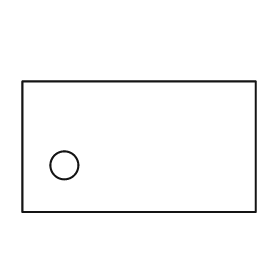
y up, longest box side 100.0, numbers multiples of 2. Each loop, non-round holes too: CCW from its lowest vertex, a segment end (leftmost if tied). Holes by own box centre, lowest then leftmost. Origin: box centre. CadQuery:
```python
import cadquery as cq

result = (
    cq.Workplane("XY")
    .moveTo(-50.0, -28.0)
    .lineTo(50.0, -28.0)
    .lineTo(50.0, 28.0)
    .lineTo(-50.0, 28.0)
    .close()
    .moveTo(-32.0, -8.0)
    .circle(6.0)
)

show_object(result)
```